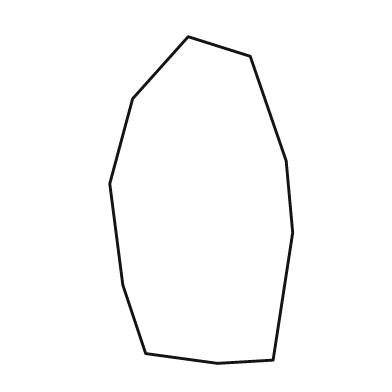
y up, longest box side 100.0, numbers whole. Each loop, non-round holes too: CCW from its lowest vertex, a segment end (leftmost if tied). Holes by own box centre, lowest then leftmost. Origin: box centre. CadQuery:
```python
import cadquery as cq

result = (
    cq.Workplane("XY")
    .moveTo(5.0, -50.0)
    .lineTo(22.0, -49.0)
    .lineTo(28.0, -10.0)
    .lineTo(26.0, 12.0)
    .lineTo(15.0, 44.0)
    .lineTo(-4.0, 50.0)
    .lineTo(-21.0, 31.0)
    .lineTo(-28.0, 5.0)
    .lineTo(-24.0, -26.0)
    .lineTo(-17.0, -47.0)
    .close()
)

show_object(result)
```